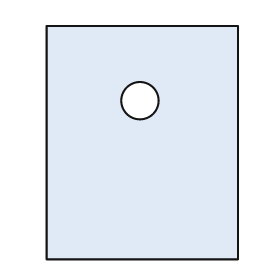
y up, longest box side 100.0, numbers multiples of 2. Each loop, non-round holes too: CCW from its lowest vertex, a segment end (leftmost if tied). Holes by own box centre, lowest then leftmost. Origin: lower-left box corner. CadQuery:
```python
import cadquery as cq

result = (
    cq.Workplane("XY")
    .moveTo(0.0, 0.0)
    .lineTo(82.0, 0.0)
    .lineTo(82.0, 100.0)
    .lineTo(0.0, 100.0)
    .close()
    .moveTo(40.0, 68.0)
    .circle(8.0)
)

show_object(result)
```